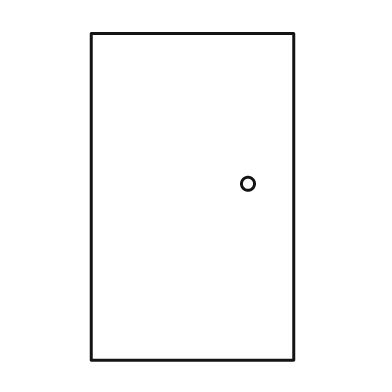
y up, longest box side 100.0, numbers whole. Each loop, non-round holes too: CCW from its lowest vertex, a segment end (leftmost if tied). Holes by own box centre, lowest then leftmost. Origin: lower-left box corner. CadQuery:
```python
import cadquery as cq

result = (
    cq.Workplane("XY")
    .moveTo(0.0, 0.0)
    .lineTo(62.0, 0.0)
    .lineTo(62.0, 100.0)
    .lineTo(0.0, 100.0)
    .close()
    .moveTo(48.0, 54.0)
    .circle(2.0)
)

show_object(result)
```